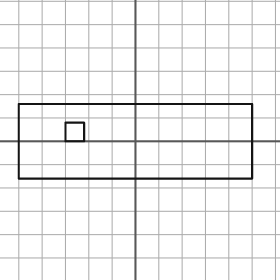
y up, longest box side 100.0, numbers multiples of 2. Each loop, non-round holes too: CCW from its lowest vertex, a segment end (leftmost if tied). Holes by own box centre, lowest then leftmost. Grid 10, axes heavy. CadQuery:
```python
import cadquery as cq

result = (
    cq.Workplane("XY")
    .moveTo(-50.0, -16.0)
    .lineTo(50.0, -16.0)
    .lineTo(50.0, 16.0)
    .lineTo(-50.0, 16.0)
    .close()
    .moveTo(-30.0, 0.0)
    .lineTo(-22.0, 0.0)
    .lineTo(-22.0, 8.0)
    .lineTo(-30.0, 8.0)
    .close()
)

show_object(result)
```